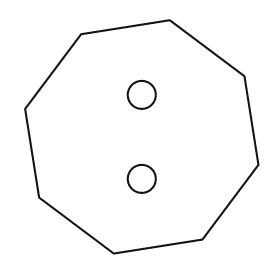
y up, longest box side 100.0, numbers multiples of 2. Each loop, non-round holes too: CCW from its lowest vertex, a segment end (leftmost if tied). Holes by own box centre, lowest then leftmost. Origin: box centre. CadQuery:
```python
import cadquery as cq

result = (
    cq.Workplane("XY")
    .moveTo(-12.0, -50.0)
    .lineTo(26.0, -44.0)
    .lineTo(50.0, -12.0)
    .lineTo(44.0, 26.0)
    .lineTo(12.0, 50.0)
    .lineTo(-26.0, 44.0)
    .lineTo(-50.0, 12.0)
    .lineTo(-44.0, -26.0)
    .close()
    .moveTo(0.0, -18.0)
    .circle(6.0)
    .moveTo(0.0, 18.0)
    .circle(6.0)
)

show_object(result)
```